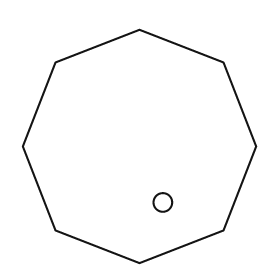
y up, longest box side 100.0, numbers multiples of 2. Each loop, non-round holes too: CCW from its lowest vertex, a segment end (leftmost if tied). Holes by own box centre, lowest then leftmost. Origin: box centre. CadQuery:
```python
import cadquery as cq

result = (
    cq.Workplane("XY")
    .moveTo(0.0, -50.0)
    .lineTo(36.0, -36.0)
    .lineTo(50.0, 0.0)
    .lineTo(36.0, 36.0)
    .lineTo(0.0, 50.0)
    .lineTo(-36.0, 36.0)
    .lineTo(-50.0, 0.0)
    .lineTo(-36.0, -36.0)
    .close()
    .moveTo(10.0, -24.0)
    .circle(4.0)
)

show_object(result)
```